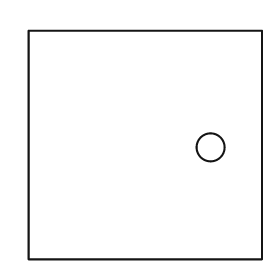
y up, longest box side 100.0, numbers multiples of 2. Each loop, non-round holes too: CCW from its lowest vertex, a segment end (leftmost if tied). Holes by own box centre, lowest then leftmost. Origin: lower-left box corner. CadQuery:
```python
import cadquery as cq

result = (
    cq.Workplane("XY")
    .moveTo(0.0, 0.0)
    .lineTo(100.0, 0.0)
    .lineTo(100.0, 98.0)
    .lineTo(0.0, 98.0)
    .close()
    .moveTo(78.0, 48.0)
    .circle(6.0)
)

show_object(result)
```